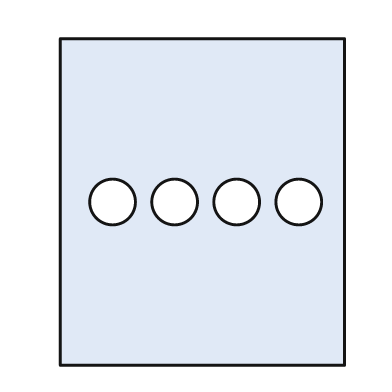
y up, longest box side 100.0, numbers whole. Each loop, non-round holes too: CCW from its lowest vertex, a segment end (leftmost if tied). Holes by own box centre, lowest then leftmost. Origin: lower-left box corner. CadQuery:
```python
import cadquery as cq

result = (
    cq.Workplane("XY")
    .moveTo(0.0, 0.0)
    .lineTo(87.0, 0.0)
    .lineTo(87.0, 100.0)
    .lineTo(0.0, 100.0)
    .close()
    .moveTo(16.0, 50.0)
    .circle(7.0)
    .moveTo(35.0, 50.0)
    .circle(7.0)
    .moveTo(54.0, 50.0)
    .circle(7.0)
    .moveTo(73.0, 50.0)
    .circle(7.0)
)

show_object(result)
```